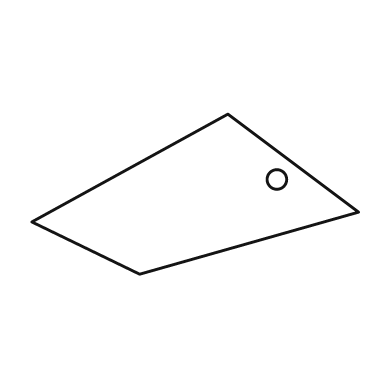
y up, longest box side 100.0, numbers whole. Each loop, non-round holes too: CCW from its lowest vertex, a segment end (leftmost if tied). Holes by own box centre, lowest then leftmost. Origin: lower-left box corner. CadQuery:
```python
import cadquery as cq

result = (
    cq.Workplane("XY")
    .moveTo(33.0, 0.0)
    .lineTo(100.0, 19.0)
    .lineTo(60.0, 49.0)
    .lineTo(0.0, 16.0)
    .close()
    .moveTo(75.0, 29.0)
    .circle(3.0)
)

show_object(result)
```